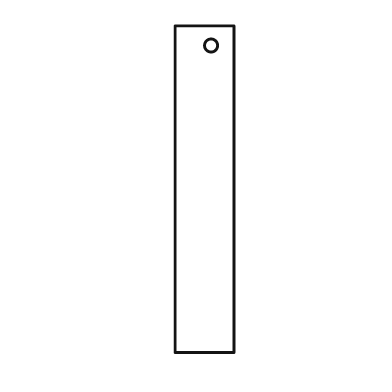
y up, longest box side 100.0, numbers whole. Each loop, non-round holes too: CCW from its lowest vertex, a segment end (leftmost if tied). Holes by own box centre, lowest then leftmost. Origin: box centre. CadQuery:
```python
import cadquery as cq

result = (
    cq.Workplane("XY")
    .moveTo(-9.0, -50.0)
    .lineTo(9.0, -50.0)
    .lineTo(9.0, 50.0)
    .lineTo(-9.0, 50.0)
    .close()
    .moveTo(2.0, 44.0)
    .circle(2.0)
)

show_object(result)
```